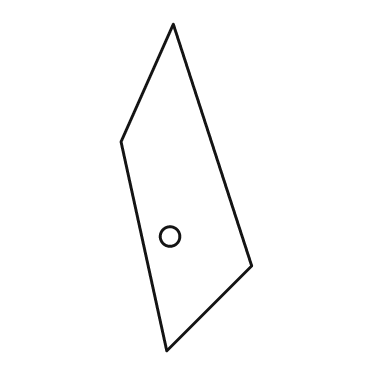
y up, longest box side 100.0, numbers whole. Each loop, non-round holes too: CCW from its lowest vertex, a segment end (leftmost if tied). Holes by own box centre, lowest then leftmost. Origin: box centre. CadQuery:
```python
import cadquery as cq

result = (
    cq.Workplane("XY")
    .moveTo(-6.0, -50.0)
    .lineTo(20.0, -24.0)
    .lineTo(-4.0, 50.0)
    .lineTo(-20.0, 14.0)
    .close()
    .moveTo(-5.0, -15.0)
    .circle(3.0)
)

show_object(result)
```